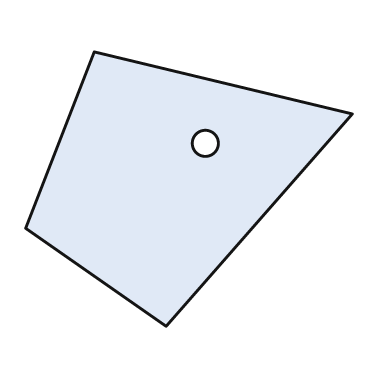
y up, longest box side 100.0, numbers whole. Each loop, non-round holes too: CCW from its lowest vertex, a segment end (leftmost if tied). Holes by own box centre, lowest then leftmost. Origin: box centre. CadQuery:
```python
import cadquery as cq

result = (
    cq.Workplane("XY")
    .moveTo(-7.0, -42.0)
    .lineTo(50.0, 23.0)
    .lineTo(-29.0, 42.0)
    .lineTo(-50.0, -12.0)
    .close()
    .moveTo(5.0, 14.0)
    .circle(4.0)
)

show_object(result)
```